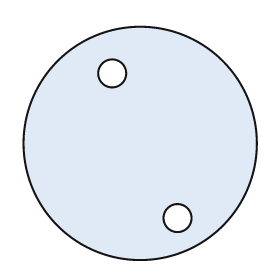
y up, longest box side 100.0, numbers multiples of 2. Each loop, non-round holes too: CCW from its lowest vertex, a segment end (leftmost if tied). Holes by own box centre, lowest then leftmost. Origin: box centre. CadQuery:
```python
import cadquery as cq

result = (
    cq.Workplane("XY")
    .moveTo(0.0, 0.0)
    .circle(50.0)
    .moveTo(16.0, -32.0)
    .circle(6.0)
    .moveTo(-12.0, 30.0)
    .circle(6.0)
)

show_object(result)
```